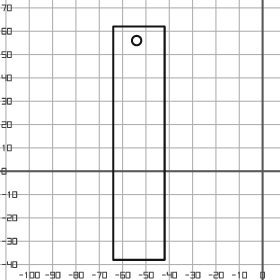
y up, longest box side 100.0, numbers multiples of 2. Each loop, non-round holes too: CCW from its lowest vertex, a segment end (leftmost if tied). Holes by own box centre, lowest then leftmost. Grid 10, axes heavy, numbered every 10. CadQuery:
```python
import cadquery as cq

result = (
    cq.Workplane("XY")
    .moveTo(-64.0, -38.0)
    .lineTo(-42.0, -38.0)
    .lineTo(-42.0, 62.0)
    .lineTo(-64.0, 62.0)
    .close()
    .moveTo(-54.0, 56.0)
    .circle(2.0)
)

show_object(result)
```